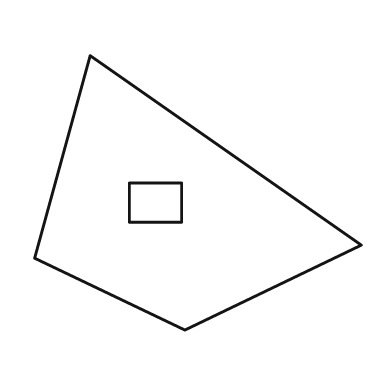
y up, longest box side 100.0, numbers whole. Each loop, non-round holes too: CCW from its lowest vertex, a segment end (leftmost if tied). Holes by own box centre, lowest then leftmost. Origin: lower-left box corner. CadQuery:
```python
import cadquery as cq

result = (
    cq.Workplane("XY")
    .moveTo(46.0, 0.0)
    .lineTo(100.0, 26.0)
    .lineTo(17.0, 84.0)
    .lineTo(0.0, 22.0)
    .close()
    .moveTo(29.0, 33.0)
    .lineTo(45.0, 33.0)
    .lineTo(45.0, 45.0)
    .lineTo(29.0, 45.0)
    .close()
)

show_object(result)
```